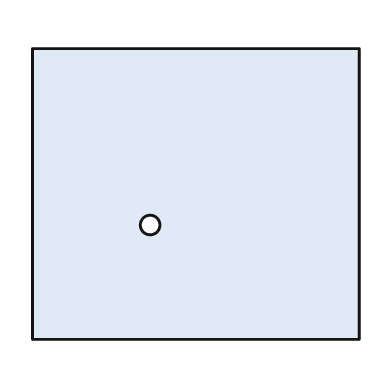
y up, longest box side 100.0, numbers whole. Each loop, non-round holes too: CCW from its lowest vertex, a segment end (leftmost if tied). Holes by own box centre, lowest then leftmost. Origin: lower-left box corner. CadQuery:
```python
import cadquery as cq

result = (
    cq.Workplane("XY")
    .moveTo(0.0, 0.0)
    .lineTo(100.0, 0.0)
    .lineTo(100.0, 89.0)
    .lineTo(0.0, 89.0)
    .close()
    .moveTo(36.0, 35.0)
    .circle(3.0)
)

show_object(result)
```